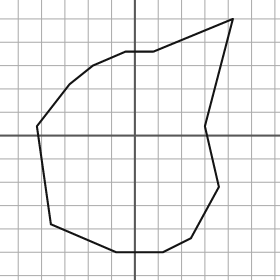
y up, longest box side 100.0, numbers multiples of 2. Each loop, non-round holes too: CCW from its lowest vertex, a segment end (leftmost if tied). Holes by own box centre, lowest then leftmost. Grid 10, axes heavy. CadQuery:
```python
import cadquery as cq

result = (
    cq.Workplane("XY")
    .moveTo(-8.0, -50.0)
    .lineTo(12.0, -50.0)
    .lineTo(24.0, -44.0)
    .lineTo(36.0, -22.0)
    .lineTo(30.0, 4.0)
    .lineTo(42.0, 50.0)
    .lineTo(8.0, 36.0)
    .lineTo(-4.0, 36.0)
    .lineTo(-18.0, 30.0)
    .lineTo(-28.0, 22.0)
    .lineTo(-42.0, 4.0)
    .lineTo(-36.0, -38.0)
    .close()
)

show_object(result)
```